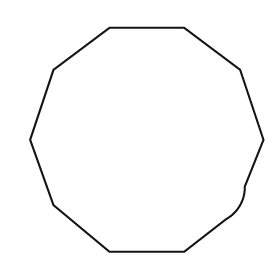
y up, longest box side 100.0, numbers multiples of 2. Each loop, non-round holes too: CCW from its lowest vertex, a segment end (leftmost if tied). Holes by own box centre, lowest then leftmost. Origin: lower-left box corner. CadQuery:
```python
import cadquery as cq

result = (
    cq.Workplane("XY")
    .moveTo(34.0, 0.0)
    .lineTo(66.0, 0.0)
    .lineTo(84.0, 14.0)
    .threePointArc((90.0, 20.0), (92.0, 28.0))
    .lineTo(100.0, 48.0)
    .lineTo(90.0, 78.0)
    .lineTo(66.0, 96.0)
    .lineTo(34.0, 96.0)
    .lineTo(10.0, 78.0)
    .lineTo(0.0, 48.0)
    .lineTo(10.0, 20.0)
    .close()
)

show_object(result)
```